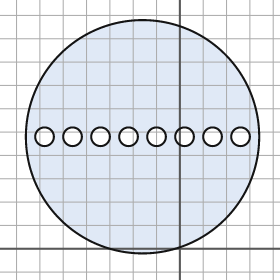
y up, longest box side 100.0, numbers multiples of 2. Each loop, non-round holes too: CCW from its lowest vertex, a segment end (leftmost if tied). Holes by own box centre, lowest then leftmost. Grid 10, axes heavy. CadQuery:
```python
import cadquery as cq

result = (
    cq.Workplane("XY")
    .moveTo(-16.0, 48.0)
    .circle(50.0)
    .moveTo(-58.0, 48.0)
    .circle(4.0)
    .moveTo(-46.0, 48.0)
    .circle(4.0)
    .moveTo(-34.0, 48.0)
    .circle(4.0)
    .moveTo(-22.0, 48.0)
    .circle(4.0)
    .moveTo(-10.0, 48.0)
    .circle(4.0)
    .moveTo(2.0, 48.0)
    .circle(4.0)
    .moveTo(14.0, 48.0)
    .circle(4.0)
    .moveTo(26.0, 48.0)
    .circle(4.0)
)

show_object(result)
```